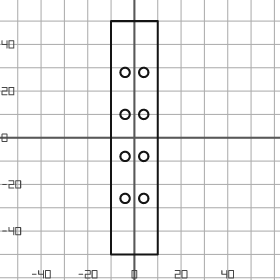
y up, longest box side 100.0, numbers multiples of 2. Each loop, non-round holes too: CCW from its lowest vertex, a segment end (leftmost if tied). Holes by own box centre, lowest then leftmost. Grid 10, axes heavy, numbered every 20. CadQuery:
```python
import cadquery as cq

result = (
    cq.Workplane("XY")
    .moveTo(-10.0, -50.0)
    .lineTo(10.0, -50.0)
    .lineTo(10.0, 50.0)
    .lineTo(-10.0, 50.0)
    .close()
    .moveTo(-4.0, -26.0)
    .circle(2.0)
    .moveTo(4.0, -26.0)
    .circle(2.0)
    .moveTo(-4.0, -8.0)
    .circle(2.0)
    .moveTo(4.0, -8.0)
    .circle(2.0)
    .moveTo(-4.0, 10.0)
    .circle(2.0)
    .moveTo(4.0, 10.0)
    .circle(2.0)
    .moveTo(-4.0, 28.0)
    .circle(2.0)
    .moveTo(4.0, 28.0)
    .circle(2.0)
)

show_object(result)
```